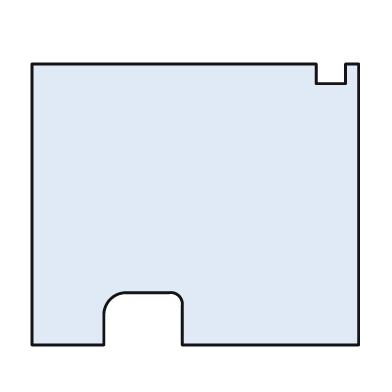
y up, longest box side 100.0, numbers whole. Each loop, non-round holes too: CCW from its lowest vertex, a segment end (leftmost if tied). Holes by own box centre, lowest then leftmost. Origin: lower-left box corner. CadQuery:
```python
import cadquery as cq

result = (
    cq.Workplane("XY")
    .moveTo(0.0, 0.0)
    .lineTo(22.0, 0.0)
    .lineTo(22.0, 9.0)
    .threePointArc((24.0, 14.0), (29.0, 16.0))
    .lineTo(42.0, 16.0)
    .threePointArc((45.0, 15.0), (46.0, 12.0))
    .lineTo(46.0, 0.0)
    .lineTo(100.0, 0.0)
    .lineTo(100.0, 86.0)
    .lineTo(96.0, 86.0)
    .lineTo(96.0, 80.0)
    .lineTo(87.0, 80.0)
    .lineTo(87.0, 86.0)
    .lineTo(0.0, 86.0)
    .close()
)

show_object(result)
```